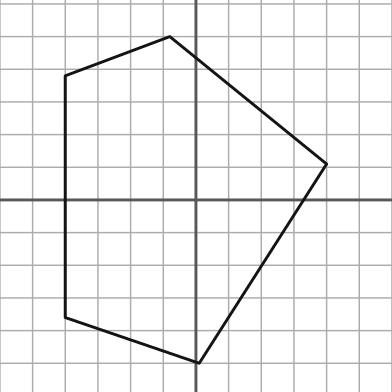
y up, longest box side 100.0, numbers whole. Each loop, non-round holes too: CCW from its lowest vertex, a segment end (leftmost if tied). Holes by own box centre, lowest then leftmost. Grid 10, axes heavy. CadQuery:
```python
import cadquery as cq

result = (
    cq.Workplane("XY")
    .moveTo(1.0, -50.0)
    .lineTo(40.0, 11.0)
    .lineTo(-8.0, 50.0)
    .lineTo(-40.0, 38.0)
    .lineTo(-40.0, -36.0)
    .close()
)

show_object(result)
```